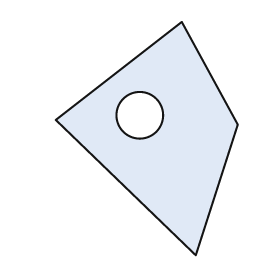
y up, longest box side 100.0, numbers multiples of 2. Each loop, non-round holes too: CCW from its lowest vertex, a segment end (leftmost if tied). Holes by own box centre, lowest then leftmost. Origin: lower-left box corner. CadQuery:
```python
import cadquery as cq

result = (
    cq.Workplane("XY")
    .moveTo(60.0, 0.0)
    .lineTo(78.0, 56.0)
    .lineTo(54.0, 100.0)
    .lineTo(0.0, 58.0)
    .close()
    .moveTo(36.0, 60.0)
    .circle(10.0)
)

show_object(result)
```